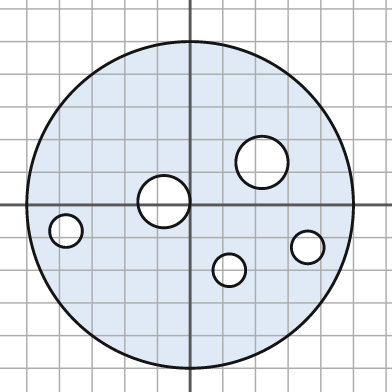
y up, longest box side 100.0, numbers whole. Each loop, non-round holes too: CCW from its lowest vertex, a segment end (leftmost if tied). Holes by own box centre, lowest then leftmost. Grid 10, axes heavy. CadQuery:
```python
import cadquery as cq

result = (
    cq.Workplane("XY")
    .moveTo(0.0, 0.0)
    .circle(50.0)
    .moveTo(12.0, -20.0)
    .circle(5.0)
    .moveTo(36.0, -13.0)
    .circle(5.0)
    .moveTo(-38.0, -8.0)
    .circle(5.0)
    .moveTo(-8.0, 1.0)
    .circle(8.0)
    .moveTo(22.0, 13.0)
    .circle(8.0)
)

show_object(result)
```